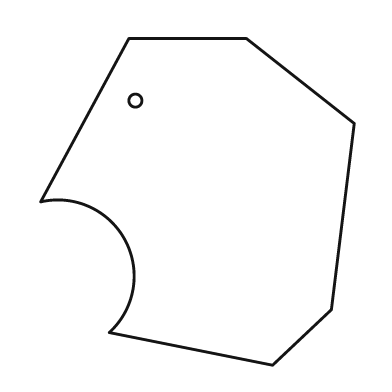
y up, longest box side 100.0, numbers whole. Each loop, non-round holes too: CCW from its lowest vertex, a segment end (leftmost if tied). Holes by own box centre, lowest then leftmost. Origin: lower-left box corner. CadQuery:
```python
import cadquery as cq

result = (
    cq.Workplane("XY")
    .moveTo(71.0, 0.0)
    .lineTo(89.0, 17.0)
    .lineTo(96.0, 74.0)
    .lineTo(63.0, 100.0)
    .lineTo(27.0, 100.0)
    .lineTo(0.0, 50.0)
    .threePointArc((26.0, 38.0), (21.0, 10.0))
    .close()
    .moveTo(29.0, 81.0)
    .circle(2.0)
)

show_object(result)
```